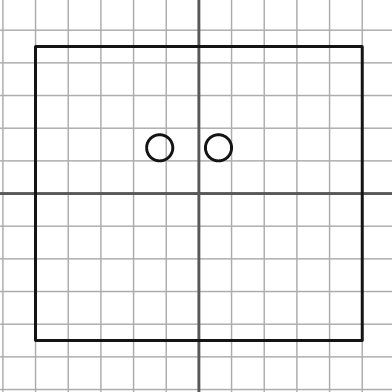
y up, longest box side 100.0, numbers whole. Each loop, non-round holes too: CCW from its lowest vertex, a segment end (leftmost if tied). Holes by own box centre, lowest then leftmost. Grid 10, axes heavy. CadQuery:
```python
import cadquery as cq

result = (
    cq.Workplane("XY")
    .moveTo(-50.0, -45.0)
    .lineTo(50.0, -45.0)
    .lineTo(50.0, 45.0)
    .lineTo(-50.0, 45.0)
    .close()
    .moveTo(-12.0, 14.0)
    .circle(4.0)
    .moveTo(6.0, 14.0)
    .circle(4.0)
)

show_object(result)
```